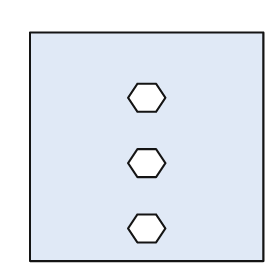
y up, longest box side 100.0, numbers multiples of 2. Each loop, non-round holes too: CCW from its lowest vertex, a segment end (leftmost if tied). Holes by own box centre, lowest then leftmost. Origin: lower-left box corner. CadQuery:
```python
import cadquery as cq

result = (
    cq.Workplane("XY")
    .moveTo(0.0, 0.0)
    .lineTo(100.0, 0.0)
    .lineTo(100.0, 98.0)
    .lineTo(0.0, 98.0)
    .close()
    .moveTo(46.0, 8.0)
    .lineTo(54.0, 8.0)
    .lineTo(58.0, 14.0)
    .lineTo(54.0, 20.0)
    .lineTo(46.0, 20.0)
    .lineTo(42.0, 14.0)
    .close()
    .moveTo(46.0, 36.0)
    .lineTo(54.0, 36.0)
    .lineTo(58.0, 42.0)
    .lineTo(54.0, 48.0)
    .lineTo(46.0, 48.0)
    .lineTo(42.0, 42.0)
    .close()
    .moveTo(46.0, 64.0)
    .lineTo(54.0, 64.0)
    .lineTo(58.0, 70.0)
    .lineTo(54.0, 76.0)
    .lineTo(46.0, 76.0)
    .lineTo(42.0, 70.0)
    .close()
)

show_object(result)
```